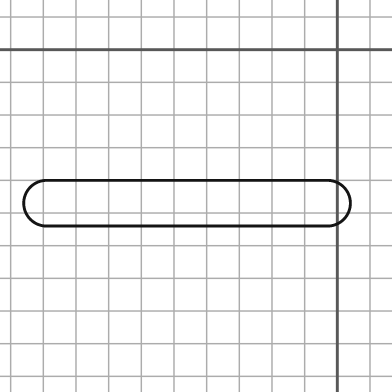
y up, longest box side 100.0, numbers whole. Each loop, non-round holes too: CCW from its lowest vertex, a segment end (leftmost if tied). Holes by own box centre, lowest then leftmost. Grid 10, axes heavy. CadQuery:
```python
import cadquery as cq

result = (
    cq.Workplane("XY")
    .moveTo(-89.0, -54.0)
    .lineTo(-3.0, -54.0)
    .threePointArc((4.0, -47.0), (-3.0, -40.0))
    .lineTo(-89.0, -40.0)
    .threePointArc((-96.0, -47.0), (-89.0, -54.0))
    .close()
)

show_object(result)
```